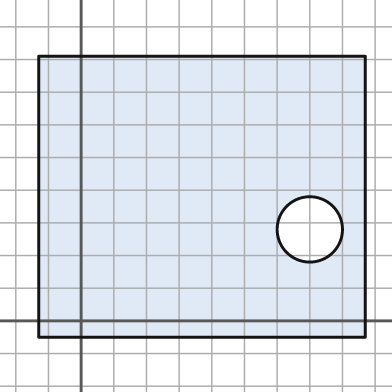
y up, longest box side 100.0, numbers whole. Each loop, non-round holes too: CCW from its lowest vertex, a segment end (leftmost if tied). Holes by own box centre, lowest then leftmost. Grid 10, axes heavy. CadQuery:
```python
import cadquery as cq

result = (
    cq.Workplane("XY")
    .moveTo(-13.0, -5.0)
    .lineTo(87.0, -5.0)
    .lineTo(87.0, 81.0)
    .lineTo(-13.0, 81.0)
    .close()
    .moveTo(70.0, 28.0)
    .circle(10.0)
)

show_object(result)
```